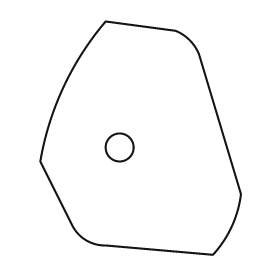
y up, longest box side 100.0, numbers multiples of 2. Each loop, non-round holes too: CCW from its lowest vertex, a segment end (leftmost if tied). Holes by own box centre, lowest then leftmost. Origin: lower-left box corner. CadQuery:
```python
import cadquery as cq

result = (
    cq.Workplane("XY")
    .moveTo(74.0, 0.0)
    .threePointArc((82.0, 12.0), (86.0, 26.0))
    .lineTo(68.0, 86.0)
    .threePointArc((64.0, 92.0), (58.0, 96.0))
    .lineTo(28.0, 100.0)
    .threePointArc((10.0, 72.0), (0.0, 40.0))
    .lineTo(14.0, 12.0)
    .threePointArc((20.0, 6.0), (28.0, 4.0))
    .close()
    .moveTo(34.0, 46.0)
    .circle(6.0)
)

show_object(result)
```